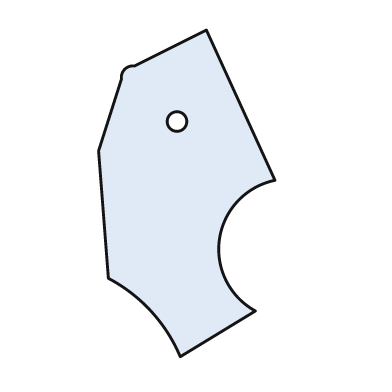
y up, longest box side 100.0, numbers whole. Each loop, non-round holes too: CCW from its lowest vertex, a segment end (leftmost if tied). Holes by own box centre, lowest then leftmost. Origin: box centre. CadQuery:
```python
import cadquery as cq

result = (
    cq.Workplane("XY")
    .moveTo(-2.0, -50.0)
    .lineTo(21.0, -36.0)
    .threePointArc((10.0, -14.0), (27.0, 4.0))
    .lineTo(6.0, 50.0)
    .lineTo(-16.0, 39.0)
    .threePointArc((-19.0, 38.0), (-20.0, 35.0))
    .lineTo(-27.0, 13.0)
    .lineTo(-24.0, -26.0)
    .threePointArc((-11.0, -36.0), (-2.0, -50.0))
    .close()
    .moveTo(-3.0, 22.0)
    .circle(3.0)
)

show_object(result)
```